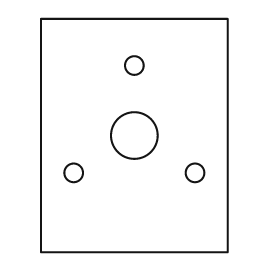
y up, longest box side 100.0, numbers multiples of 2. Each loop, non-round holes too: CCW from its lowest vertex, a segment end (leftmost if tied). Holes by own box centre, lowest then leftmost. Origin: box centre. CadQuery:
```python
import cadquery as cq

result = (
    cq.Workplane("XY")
    .moveTo(-40.0, -50.0)
    .lineTo(40.0, -50.0)
    .lineTo(40.0, 50.0)
    .lineTo(-40.0, 50.0)
    .close()
    .moveTo(-26.0, -16.0)
    .circle(4.0)
    .moveTo(26.0, -16.0)
    .circle(4.0)
    .moveTo(0.0, 0.0)
    .circle(10.0)
    .moveTo(0.0, 30.0)
    .circle(4.0)
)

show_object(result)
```